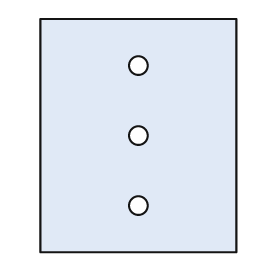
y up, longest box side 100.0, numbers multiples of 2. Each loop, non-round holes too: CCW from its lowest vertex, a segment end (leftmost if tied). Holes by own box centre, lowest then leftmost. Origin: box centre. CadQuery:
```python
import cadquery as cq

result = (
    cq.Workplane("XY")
    .moveTo(-42.0, -50.0)
    .lineTo(42.0, -50.0)
    .lineTo(42.0, 50.0)
    .lineTo(-42.0, 50.0)
    .close()
    .moveTo(0.0, -30.0)
    .circle(4.0)
    .moveTo(0.0, 0.0)
    .circle(4.0)
    .moveTo(0.0, 30.0)
    .circle(4.0)
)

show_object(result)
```